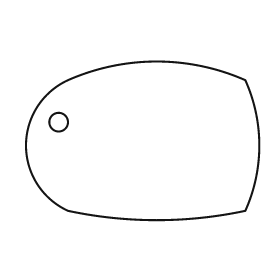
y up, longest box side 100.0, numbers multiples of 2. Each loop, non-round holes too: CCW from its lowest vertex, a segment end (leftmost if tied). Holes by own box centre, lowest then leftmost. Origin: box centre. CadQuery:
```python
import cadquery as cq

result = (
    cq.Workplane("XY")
    .moveTo(-32.0, -30.0)
    .threePointArc((6.0, -34.0), (44.0, -30.0))
    .threePointArc((50.0, -2.0), (44.0, 26.0))
    .threePointArc((6.0, 34.0), (-32.0, 26.0))
    .threePointArc((-50.0, -2.0), (-32.0, -30.0))
    .close()
    .moveTo(-36.0, 8.0)
    .circle(4.0)
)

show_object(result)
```